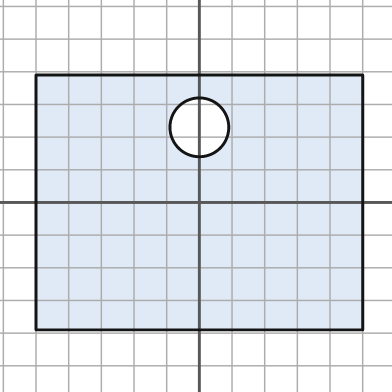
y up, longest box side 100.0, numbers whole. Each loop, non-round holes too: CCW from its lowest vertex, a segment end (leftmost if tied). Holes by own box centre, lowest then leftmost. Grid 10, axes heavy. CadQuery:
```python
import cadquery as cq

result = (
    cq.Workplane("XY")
    .moveTo(-50.0, -39.0)
    .lineTo(50.0, -39.0)
    .lineTo(50.0, 39.0)
    .lineTo(-50.0, 39.0)
    .close()
    .moveTo(0.0, 23.0)
    .circle(9.0)
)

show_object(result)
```